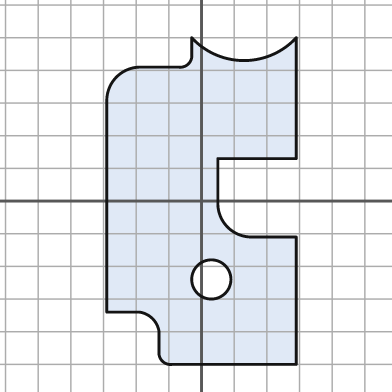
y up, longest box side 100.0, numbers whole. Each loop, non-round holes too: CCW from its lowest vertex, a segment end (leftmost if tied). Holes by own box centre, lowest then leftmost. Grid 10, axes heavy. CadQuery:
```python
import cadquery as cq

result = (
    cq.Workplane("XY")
    .moveTo(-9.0, -50.0)
    .lineTo(29.0, -50.0)
    .lineTo(29.0, -11.0)
    .lineTo(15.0, -11.0)
    .threePointArc((8.0, -8.0), (5.0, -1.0))
    .lineTo(5.0, 13.0)
    .lineTo(29.0, 13.0)
    .lineTo(29.0, 50.0)
    .threePointArc((13.0, 43.0), (-3.0, 50.0))
    .lineTo(-3.0, 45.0)
    .threePointArc((-4.0, 42.0), (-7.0, 41.0))
    .lineTo(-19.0, 41.0)
    .threePointArc((-26.0, 38.0), (-29.0, 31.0))
    .lineTo(-29.0, -34.0)
    .lineTo(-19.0, -34.0)
    .threePointArc((-15.0, -36.0), (-13.0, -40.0))
    .lineTo(-13.0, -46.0)
    .threePointArc((-12.0, -49.0), (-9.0, -50.0))
    .close()
    .moveTo(3.0, -24.0)
    .circle(6.0)
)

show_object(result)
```